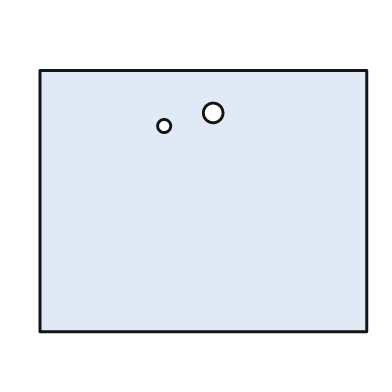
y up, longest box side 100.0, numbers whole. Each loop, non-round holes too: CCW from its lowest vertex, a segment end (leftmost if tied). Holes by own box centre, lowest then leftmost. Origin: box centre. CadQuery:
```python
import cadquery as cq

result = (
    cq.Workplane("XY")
    .moveTo(-50.0, -40.0)
    .lineTo(50.0, -40.0)
    .lineTo(50.0, 40.0)
    .lineTo(-50.0, 40.0)
    .close()
    .moveTo(-12.0, 23.0)
    .circle(2.0)
    .moveTo(3.0, 27.0)
    .circle(3.0)
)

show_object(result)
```